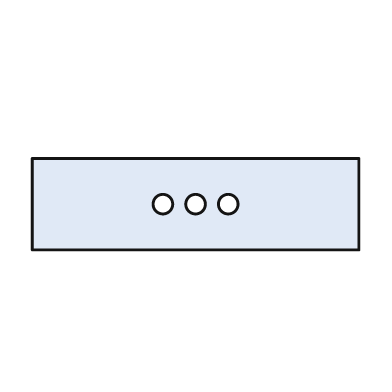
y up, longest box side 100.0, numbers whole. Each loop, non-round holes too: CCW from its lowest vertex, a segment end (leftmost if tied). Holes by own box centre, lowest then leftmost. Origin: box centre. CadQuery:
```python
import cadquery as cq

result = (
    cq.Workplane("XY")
    .moveTo(-50.0, -14.0)
    .lineTo(50.0, -14.0)
    .lineTo(50.0, 14.0)
    .lineTo(-50.0, 14.0)
    .close()
    .moveTo(-10.0, 0.0)
    .circle(3.0)
    .moveTo(0.0, 0.0)
    .circle(3.0)
    .moveTo(10.0, 0.0)
    .circle(3.0)
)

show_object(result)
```